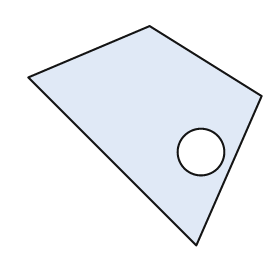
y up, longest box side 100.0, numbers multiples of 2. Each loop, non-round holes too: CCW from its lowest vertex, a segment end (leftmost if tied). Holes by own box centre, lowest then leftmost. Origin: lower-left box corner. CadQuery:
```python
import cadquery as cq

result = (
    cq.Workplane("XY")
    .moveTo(72.0, 0.0)
    .lineTo(100.0, 64.0)
    .lineTo(52.0, 94.0)
    .lineTo(0.0, 72.0)
    .close()
    .moveTo(74.0, 40.0)
    .circle(10.0)
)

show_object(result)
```